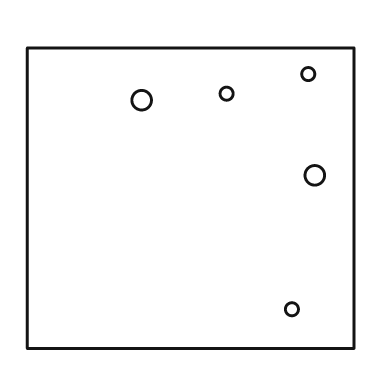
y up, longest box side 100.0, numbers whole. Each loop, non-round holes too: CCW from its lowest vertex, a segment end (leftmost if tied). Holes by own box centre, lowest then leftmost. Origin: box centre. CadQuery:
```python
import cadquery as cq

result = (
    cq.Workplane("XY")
    .moveTo(-50.0, -46.0)
    .lineTo(50.0, -46.0)
    .lineTo(50.0, 46.0)
    .lineTo(-50.0, 46.0)
    .close()
    .moveTo(31.0, -34.0)
    .circle(2.0)
    .moveTo(38.0, 7.0)
    .circle(3.0)
    .moveTo(-15.0, 30.0)
    .circle(3.0)
    .moveTo(11.0, 32.0)
    .circle(2.0)
    .moveTo(36.0, 38.0)
    .circle(2.0)
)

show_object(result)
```